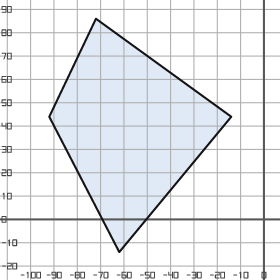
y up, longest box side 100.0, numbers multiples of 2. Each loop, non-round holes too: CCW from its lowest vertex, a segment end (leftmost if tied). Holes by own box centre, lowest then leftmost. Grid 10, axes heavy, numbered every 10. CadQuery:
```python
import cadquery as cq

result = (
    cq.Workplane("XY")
    .moveTo(-62.0, -14.0)
    .lineTo(-14.0, 44.0)
    .lineTo(-72.0, 86.0)
    .lineTo(-92.0, 44.0)
    .close()
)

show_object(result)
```